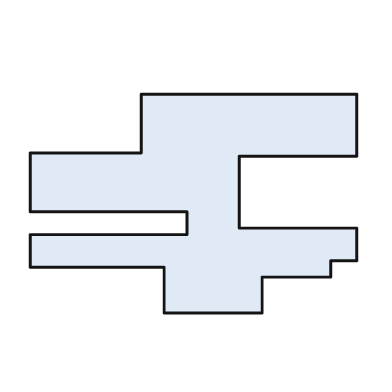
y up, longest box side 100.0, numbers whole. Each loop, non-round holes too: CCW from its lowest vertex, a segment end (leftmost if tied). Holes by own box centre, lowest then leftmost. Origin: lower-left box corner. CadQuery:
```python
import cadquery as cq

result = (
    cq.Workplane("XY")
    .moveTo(41.0, 0.0)
    .lineTo(71.0, 0.0)
    .lineTo(71.0, 11.0)
    .lineTo(92.0, 11.0)
    .lineTo(92.0, 16.0)
    .lineTo(100.0, 16.0)
    .lineTo(100.0, 26.0)
    .lineTo(64.0, 26.0)
    .lineTo(64.0, 48.0)
    .lineTo(100.0, 48.0)
    .lineTo(100.0, 67.0)
    .lineTo(34.0, 67.0)
    .lineTo(34.0, 49.0)
    .lineTo(0.0, 49.0)
    .lineTo(0.0, 31.0)
    .lineTo(48.0, 31.0)
    .lineTo(48.0, 24.0)
    .lineTo(0.0, 24.0)
    .lineTo(0.0, 14.0)
    .lineTo(41.0, 14.0)
    .close()
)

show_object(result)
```